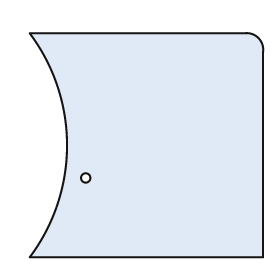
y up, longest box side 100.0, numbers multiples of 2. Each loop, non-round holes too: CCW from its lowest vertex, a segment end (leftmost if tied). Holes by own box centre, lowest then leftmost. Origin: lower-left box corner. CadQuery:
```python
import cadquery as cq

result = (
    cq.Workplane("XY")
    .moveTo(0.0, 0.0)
    .lineTo(100.0, 0.0)
    .lineTo(100.0, 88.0)
    .threePointArc((98.0, 94.0), (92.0, 96.0))
    .lineTo(0.0, 96.0)
    .threePointArc((16.0, 48.0), (0.0, 0.0))
    .close()
    .moveTo(24.0, 34.0)
    .circle(2.0)
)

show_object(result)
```